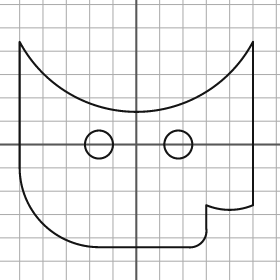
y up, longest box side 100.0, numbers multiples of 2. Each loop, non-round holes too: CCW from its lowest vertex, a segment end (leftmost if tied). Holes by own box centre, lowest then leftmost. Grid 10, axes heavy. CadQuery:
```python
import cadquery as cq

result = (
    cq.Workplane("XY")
    .moveTo(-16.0, -44.0)
    .lineTo(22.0, -44.0)
    .threePointArc((28.0, -42.0), (30.0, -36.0))
    .lineTo(30.0, -26.0)
    .threePointArc((40.0, -28.0), (50.0, -26.0))
    .lineTo(50.0, 44.0)
    .threePointArc((0.0, 14.0), (-50.0, 44.0))
    .lineTo(-50.0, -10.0)
    .threePointArc((-40.0, -34.0), (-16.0, -44.0))
    .close()
    .moveTo(-16.0, 0.0)
    .circle(6.0)
    .moveTo(18.0, 0.0)
    .circle(6.0)
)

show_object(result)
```